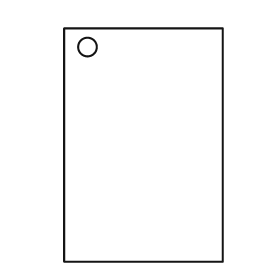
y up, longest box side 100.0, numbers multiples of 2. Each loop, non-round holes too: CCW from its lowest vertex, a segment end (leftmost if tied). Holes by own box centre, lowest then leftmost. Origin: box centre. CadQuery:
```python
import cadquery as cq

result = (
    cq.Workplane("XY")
    .moveTo(-34.0, -50.0)
    .lineTo(34.0, -50.0)
    .lineTo(34.0, 50.0)
    .lineTo(-34.0, 50.0)
    .close()
    .moveTo(-24.0, 42.0)
    .circle(4.0)
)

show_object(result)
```